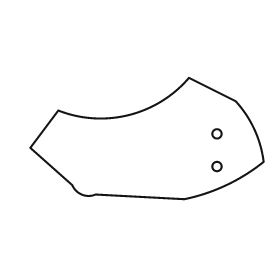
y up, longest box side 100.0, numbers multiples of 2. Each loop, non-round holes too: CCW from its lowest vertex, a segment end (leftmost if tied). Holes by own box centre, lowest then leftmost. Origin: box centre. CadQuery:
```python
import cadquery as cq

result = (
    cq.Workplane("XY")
    .moveTo(16.0, -26.0)
    .threePointArc((34.0, -20.0), (50.0, -10.0))
    .threePointArc((46.0, 4.0), (38.0, 16.0))
    .lineTo(18.0, 26.0)
    .threePointArc((-8.0, 10.0), (-38.0, 12.0))
    .lineTo(-50.0, -4.0)
    .lineTo(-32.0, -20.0)
    .threePointArc((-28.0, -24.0), (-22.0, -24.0))
    .close()
    .moveTo(30.0, -12.0)
    .circle(2.0)
    .moveTo(30.0, 2.0)
    .circle(2.0)
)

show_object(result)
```